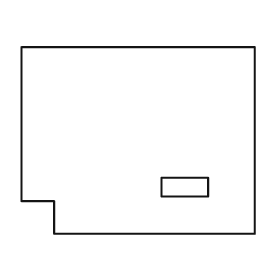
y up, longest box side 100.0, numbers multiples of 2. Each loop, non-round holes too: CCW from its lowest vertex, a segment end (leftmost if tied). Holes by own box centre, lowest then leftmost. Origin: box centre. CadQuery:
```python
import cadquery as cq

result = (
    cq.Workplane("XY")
    .moveTo(-36.0, -40.0)
    .lineTo(50.0, -40.0)
    .lineTo(50.0, 40.0)
    .lineTo(-50.0, 40.0)
    .lineTo(-50.0, -26.0)
    .lineTo(-36.0, -26.0)
    .close()
    .moveTo(10.0, -24.0)
    .lineTo(30.0, -24.0)
    .lineTo(30.0, -16.0)
    .lineTo(10.0, -16.0)
    .close()
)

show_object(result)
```